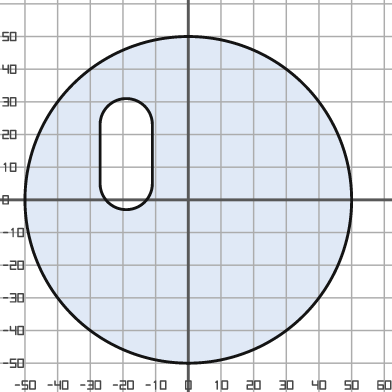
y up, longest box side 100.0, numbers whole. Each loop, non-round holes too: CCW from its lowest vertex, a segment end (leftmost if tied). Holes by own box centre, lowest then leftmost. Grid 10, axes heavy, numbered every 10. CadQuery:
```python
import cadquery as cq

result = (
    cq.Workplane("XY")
    .moveTo(0.0, 0.0)
    .circle(50.0)
    .moveTo(-27.0, 5.0)
    .threePointArc((-19.0, -3.0), (-11.0, 5.0))
    .lineTo(-11.0, 23.0)
    .threePointArc((-19.0, 31.0), (-27.0, 23.0))
    .close()
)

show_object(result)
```